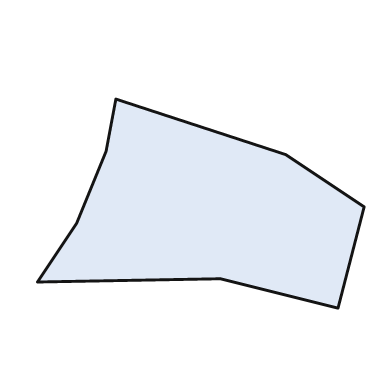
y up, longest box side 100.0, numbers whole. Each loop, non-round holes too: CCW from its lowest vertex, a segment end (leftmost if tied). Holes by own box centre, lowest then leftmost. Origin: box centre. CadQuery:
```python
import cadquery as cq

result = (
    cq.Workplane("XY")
    .moveTo(42.0, -32.0)
    .lineTo(50.0, -1.0)
    .lineTo(26.0, 15.0)
    .lineTo(-26.0, 32.0)
    .lineTo(-29.0, 16.0)
    .lineTo(-38.0, -6.0)
    .lineTo(-50.0, -24.0)
    .lineTo(6.0, -23.0)
    .close()
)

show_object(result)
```